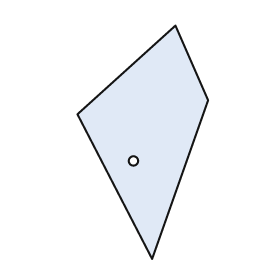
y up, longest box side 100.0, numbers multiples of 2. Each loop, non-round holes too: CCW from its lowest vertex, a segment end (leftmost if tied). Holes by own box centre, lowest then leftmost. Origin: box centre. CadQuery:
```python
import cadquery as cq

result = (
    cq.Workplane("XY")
    .moveTo(4.0, -50.0)
    .lineTo(28.0, 18.0)
    .lineTo(14.0, 50.0)
    .lineTo(-28.0, 12.0)
    .close()
    .moveTo(-4.0, -8.0)
    .circle(2.0)
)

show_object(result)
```